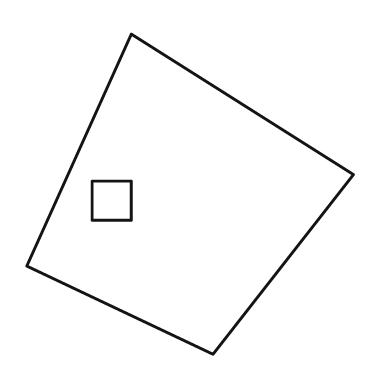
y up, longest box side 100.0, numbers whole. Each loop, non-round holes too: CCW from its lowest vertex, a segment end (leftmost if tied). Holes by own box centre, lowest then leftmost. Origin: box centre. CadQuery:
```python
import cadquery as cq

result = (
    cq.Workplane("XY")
    .moveTo(7.0, -49.0)
    .lineTo(50.0, 6.0)
    .lineTo(-18.0, 49.0)
    .lineTo(-50.0, -22.0)
    .close()
    .moveTo(-30.0, -8.0)
    .lineTo(-18.0, -8.0)
    .lineTo(-18.0, 4.0)
    .lineTo(-30.0, 4.0)
    .close()
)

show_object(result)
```